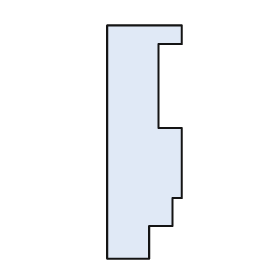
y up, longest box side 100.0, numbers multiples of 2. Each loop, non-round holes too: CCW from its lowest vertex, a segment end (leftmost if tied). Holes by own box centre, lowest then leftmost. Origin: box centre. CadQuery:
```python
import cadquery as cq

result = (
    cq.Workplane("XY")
    .moveTo(-16.0, -50.0)
    .lineTo(2.0, -50.0)
    .lineTo(2.0, -36.0)
    .lineTo(12.0, -36.0)
    .lineTo(12.0, -24.0)
    .lineTo(16.0, -24.0)
    .lineTo(16.0, 6.0)
    .lineTo(6.0, 6.0)
    .lineTo(6.0, 42.0)
    .lineTo(16.0, 42.0)
    .lineTo(16.0, 50.0)
    .lineTo(-16.0, 50.0)
    .close()
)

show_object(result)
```